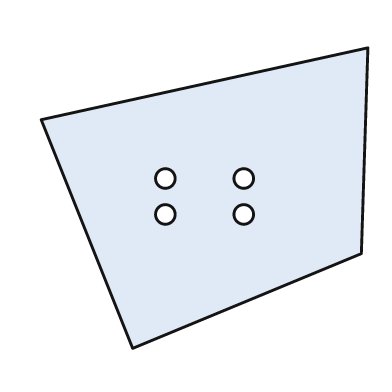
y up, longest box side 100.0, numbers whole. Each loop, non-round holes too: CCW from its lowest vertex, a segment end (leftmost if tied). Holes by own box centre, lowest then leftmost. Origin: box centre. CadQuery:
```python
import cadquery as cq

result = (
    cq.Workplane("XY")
    .moveTo(-22.0, -46.0)
    .lineTo(48.0, -17.0)
    .lineTo(50.0, 46.0)
    .lineTo(-50.0, 24.0)
    .close()
    .moveTo(-12.0, -5.0)
    .circle(3.0)
    .moveTo(12.0, -5.0)
    .circle(3.0)
    .moveTo(-12.0, 6.0)
    .circle(3.0)
    .moveTo(12.0, 6.0)
    .circle(3.0)
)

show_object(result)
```